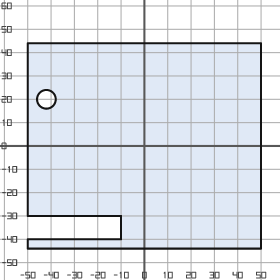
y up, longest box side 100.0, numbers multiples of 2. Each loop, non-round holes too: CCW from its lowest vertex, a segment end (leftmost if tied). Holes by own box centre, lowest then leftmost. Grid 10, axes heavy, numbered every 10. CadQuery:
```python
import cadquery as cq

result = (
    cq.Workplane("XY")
    .moveTo(-50.0, -44.0)
    .lineTo(50.0, -44.0)
    .lineTo(50.0, 44.0)
    .lineTo(-50.0, 44.0)
    .lineTo(-50.0, -30.0)
    .lineTo(-10.0, -30.0)
    .lineTo(-10.0, -40.0)
    .lineTo(-50.0, -40.0)
    .close()
    .moveTo(-42.0, 20.0)
    .circle(4.0)
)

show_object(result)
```